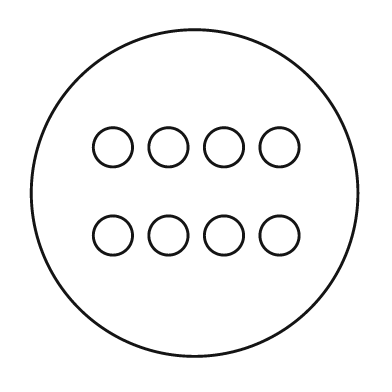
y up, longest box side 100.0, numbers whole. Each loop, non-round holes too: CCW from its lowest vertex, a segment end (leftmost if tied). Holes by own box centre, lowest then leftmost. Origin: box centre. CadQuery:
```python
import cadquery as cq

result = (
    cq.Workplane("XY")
    .moveTo(0.0, 0.0)
    .circle(50.0)
    .moveTo(-25.0, -13.0)
    .circle(6.0)
    .moveTo(-8.0, -13.0)
    .circle(6.0)
    .moveTo(9.0, -13.0)
    .circle(6.0)
    .moveTo(26.0, -13.0)
    .circle(6.0)
    .moveTo(-25.0, 14.0)
    .circle(6.0)
    .moveTo(-8.0, 14.0)
    .circle(6.0)
    .moveTo(9.0, 14.0)
    .circle(6.0)
    .moveTo(26.0, 14.0)
    .circle(6.0)
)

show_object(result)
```